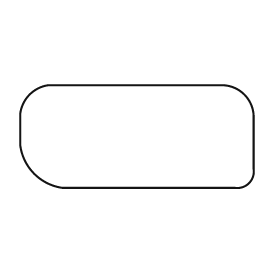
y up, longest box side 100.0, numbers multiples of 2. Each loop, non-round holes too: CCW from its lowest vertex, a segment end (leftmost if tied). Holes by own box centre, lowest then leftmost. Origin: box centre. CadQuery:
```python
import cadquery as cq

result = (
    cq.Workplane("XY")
    .moveTo(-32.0, -22.0)
    .lineTo(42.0, -22.0)
    .threePointArc((48.0, -20.0), (50.0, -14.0))
    .lineTo(50.0, 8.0)
    .threePointArc((46.0, 18.0), (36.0, 22.0))
    .lineTo(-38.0, 22.0)
    .threePointArc((-46.0, 18.0), (-50.0, 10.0))
    .lineTo(-50.0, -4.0)
    .threePointArc((-44.0, -16.0), (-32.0, -22.0))
    .close()
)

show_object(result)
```